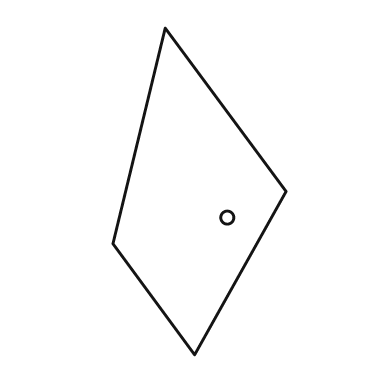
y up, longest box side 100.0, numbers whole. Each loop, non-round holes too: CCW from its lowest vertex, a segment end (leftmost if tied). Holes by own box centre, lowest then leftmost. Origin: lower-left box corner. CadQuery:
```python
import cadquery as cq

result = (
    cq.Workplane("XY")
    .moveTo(25.0, 0.0)
    .lineTo(53.0, 50.0)
    .lineTo(16.0, 100.0)
    .lineTo(0.0, 34.0)
    .close()
    .moveTo(35.0, 42.0)
    .circle(2.0)
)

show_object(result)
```